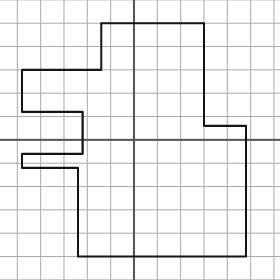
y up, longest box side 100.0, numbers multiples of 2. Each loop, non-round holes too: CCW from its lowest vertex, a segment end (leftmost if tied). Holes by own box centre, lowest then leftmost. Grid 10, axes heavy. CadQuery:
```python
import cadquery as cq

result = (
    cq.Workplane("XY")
    .moveTo(-24.0, -50.0)
    .lineTo(48.0, -50.0)
    .lineTo(48.0, 6.0)
    .lineTo(30.0, 6.0)
    .lineTo(30.0, 50.0)
    .lineTo(-14.0, 50.0)
    .lineTo(-14.0, 30.0)
    .lineTo(-48.0, 30.0)
    .lineTo(-48.0, 12.0)
    .lineTo(-22.0, 12.0)
    .lineTo(-22.0, -6.0)
    .lineTo(-48.0, -6.0)
    .lineTo(-48.0, -12.0)
    .lineTo(-24.0, -12.0)
    .close()
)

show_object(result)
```